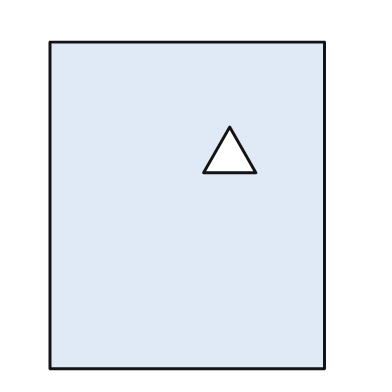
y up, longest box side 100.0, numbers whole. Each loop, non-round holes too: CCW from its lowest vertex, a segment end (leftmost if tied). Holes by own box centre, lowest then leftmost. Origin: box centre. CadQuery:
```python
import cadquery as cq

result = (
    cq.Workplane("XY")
    .moveTo(-42.0, -50.0)
    .lineTo(42.0, -50.0)
    .lineTo(42.0, 50.0)
    .lineTo(-42.0, 50.0)
    .close()
    .moveTo(5.0, 10.0)
    .lineTo(21.0, 10.0)
    .lineTo(13.0, 24.0)
    .close()
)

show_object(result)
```